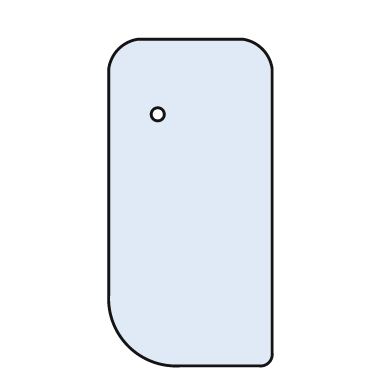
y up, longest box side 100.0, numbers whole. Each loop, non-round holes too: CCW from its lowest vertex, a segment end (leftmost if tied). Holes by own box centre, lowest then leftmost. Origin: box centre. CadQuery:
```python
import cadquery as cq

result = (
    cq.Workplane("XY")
    .moveTo(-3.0, -50.0)
    .lineTo(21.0, -50.0)
    .threePointArc((24.0, -49.0), (25.0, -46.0))
    .lineTo(25.0, 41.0)
    .threePointArc((22.0, 47.0), (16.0, 50.0))
    .lineTo(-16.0, 50.0)
    .threePointArc((-22.0, 47.0), (-25.0, 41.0))
    .lineTo(-25.0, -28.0)
    .threePointArc((-19.0, -44.0), (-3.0, -50.0))
    .close()
    .moveTo(-10.0, 27.0)
    .circle(2.0)
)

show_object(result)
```